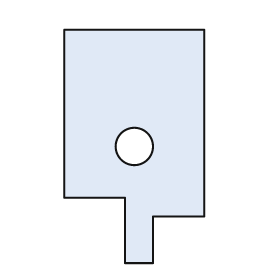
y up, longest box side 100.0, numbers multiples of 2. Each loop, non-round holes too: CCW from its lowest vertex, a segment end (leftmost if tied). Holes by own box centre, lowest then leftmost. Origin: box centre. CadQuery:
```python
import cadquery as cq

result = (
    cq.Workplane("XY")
    .moveTo(-4.0, -50.0)
    .lineTo(8.0, -50.0)
    .lineTo(8.0, -30.0)
    .lineTo(30.0, -30.0)
    .lineTo(30.0, 50.0)
    .lineTo(-30.0, 50.0)
    .lineTo(-30.0, -22.0)
    .lineTo(-4.0, -22.0)
    .close()
    .moveTo(0.0, 0.0)
    .circle(8.0)
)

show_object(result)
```